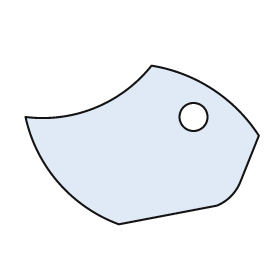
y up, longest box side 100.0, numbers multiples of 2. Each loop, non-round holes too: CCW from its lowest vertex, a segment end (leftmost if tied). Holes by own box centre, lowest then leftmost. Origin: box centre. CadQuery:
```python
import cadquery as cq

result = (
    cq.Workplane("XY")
    .moveTo(-10.0, -34.0)
    .lineTo(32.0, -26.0)
    .threePointArc((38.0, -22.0), (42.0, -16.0))
    .lineTo(50.0, 4.0)
    .threePointArc((30.0, 24.0), (4.0, 34.0))
    .threePointArc((-20.0, 16.0), (-50.0, 12.0))
    .threePointArc((-36.0, -16.0), (-10.0, -34.0))
    .close()
    .moveTo(22.0, 12.0)
    .circle(6.0)
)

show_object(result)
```